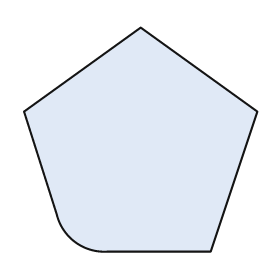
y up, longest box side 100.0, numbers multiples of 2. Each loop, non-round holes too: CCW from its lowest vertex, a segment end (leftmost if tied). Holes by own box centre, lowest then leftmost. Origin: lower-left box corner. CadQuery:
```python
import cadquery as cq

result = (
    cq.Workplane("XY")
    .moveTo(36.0, 0.0)
    .lineTo(80.0, 0.0)
    .lineTo(100.0, 60.0)
    .lineTo(50.0, 96.0)
    .lineTo(0.0, 60.0)
    .lineTo(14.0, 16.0)
    .threePointArc((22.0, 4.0), (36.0, 0.0))
    .close()
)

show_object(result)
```